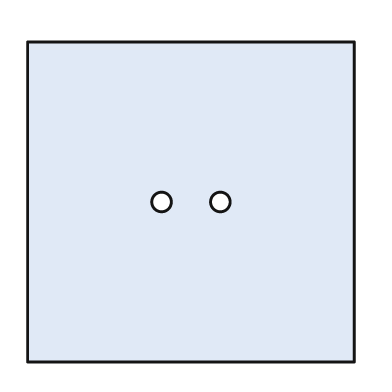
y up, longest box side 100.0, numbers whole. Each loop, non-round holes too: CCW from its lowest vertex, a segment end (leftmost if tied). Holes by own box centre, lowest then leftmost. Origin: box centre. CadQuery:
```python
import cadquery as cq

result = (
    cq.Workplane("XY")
    .moveTo(-50.0, -49.0)
    .lineTo(50.0, -49.0)
    .lineTo(50.0, 49.0)
    .lineTo(-50.0, 49.0)
    .close()
    .moveTo(-9.0, 0.0)
    .circle(3.0)
    .moveTo(9.0, 0.0)
    .circle(3.0)
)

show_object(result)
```